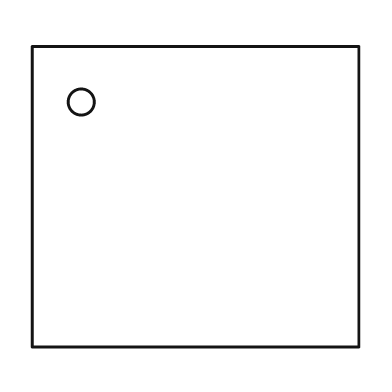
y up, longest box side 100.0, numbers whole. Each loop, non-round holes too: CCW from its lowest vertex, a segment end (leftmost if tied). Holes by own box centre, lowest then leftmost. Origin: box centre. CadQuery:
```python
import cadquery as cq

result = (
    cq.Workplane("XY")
    .moveTo(-50.0, -46.0)
    .lineTo(50.0, -46.0)
    .lineTo(50.0, 46.0)
    .lineTo(-50.0, 46.0)
    .close()
    .moveTo(-35.0, 29.0)
    .circle(4.0)
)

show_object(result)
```